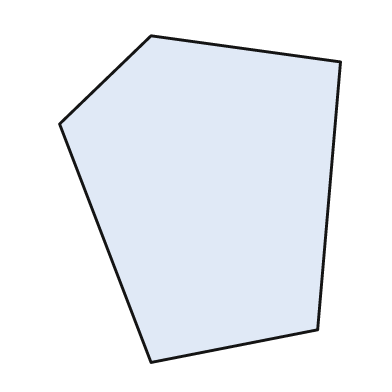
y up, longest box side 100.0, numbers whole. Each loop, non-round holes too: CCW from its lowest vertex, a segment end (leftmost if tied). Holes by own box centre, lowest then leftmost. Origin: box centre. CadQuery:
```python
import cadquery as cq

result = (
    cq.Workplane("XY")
    .moveTo(-15.0, -50.0)
    .lineTo(36.0, -40.0)
    .lineTo(43.0, 42.0)
    .lineTo(-15.0, 50.0)
    .lineTo(-43.0, 23.0)
    .close()
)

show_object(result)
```